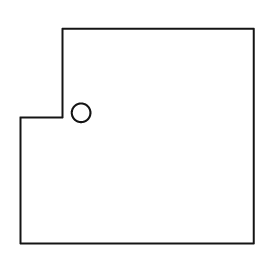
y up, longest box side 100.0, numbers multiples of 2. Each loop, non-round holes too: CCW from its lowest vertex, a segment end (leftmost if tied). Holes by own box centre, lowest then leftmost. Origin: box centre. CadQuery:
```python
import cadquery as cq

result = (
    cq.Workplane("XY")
    .moveTo(-50.0, -46.0)
    .lineTo(50.0, -46.0)
    .lineTo(50.0, 46.0)
    .lineTo(-32.0, 46.0)
    .lineTo(-32.0, 8.0)
    .lineTo(-50.0, 8.0)
    .close()
    .moveTo(-24.0, 10.0)
    .circle(4.0)
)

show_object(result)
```